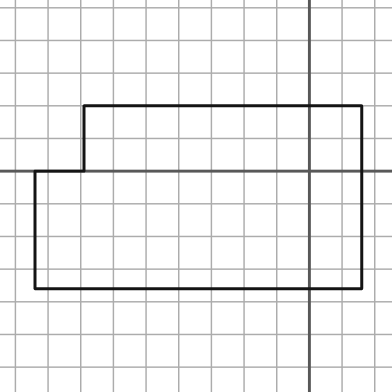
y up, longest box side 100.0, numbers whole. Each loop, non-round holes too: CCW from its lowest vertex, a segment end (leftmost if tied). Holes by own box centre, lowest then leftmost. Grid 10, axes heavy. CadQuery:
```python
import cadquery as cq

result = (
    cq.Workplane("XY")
    .moveTo(-84.0, -36.0)
    .lineTo(16.0, -36.0)
    .lineTo(16.0, 20.0)
    .lineTo(-69.0, 20.0)
    .lineTo(-69.0, 0.0)
    .lineTo(-84.0, 0.0)
    .close()
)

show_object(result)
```